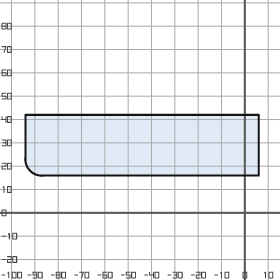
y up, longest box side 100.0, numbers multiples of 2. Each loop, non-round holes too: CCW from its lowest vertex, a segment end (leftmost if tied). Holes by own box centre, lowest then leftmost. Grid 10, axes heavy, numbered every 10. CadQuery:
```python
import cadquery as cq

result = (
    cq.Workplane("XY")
    .moveTo(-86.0, 16.0)
    .lineTo(6.0, 16.0)
    .lineTo(6.0, 42.0)
    .lineTo(-94.0, 42.0)
    .lineTo(-94.0, 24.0)
    .threePointArc((-92.0, 18.0), (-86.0, 16.0))
    .close()
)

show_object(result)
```